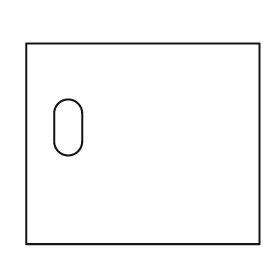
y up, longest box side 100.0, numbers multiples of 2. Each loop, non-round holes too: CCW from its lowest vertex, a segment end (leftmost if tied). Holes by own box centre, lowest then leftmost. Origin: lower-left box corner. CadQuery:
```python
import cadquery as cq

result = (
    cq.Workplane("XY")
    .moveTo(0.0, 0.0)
    .lineTo(100.0, 0.0)
    .lineTo(100.0, 86.0)
    .lineTo(0.0, 86.0)
    .close()
    .moveTo(12.0, 44.0)
    .threePointArc((18.0, 38.0), (24.0, 44.0))
    .lineTo(24.0, 56.0)
    .threePointArc((18.0, 62.0), (12.0, 56.0))
    .close()
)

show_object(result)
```